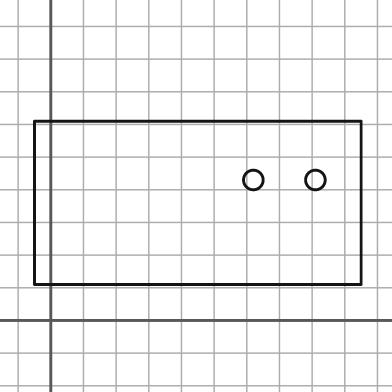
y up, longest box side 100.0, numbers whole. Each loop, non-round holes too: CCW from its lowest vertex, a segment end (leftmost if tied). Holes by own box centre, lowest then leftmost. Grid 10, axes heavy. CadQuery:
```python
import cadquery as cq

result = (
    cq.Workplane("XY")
    .moveTo(-5.0, 11.0)
    .lineTo(95.0, 11.0)
    .lineTo(95.0, 61.0)
    .lineTo(-5.0, 61.0)
    .close()
    .moveTo(62.0, 43.0)
    .circle(3.0)
    .moveTo(81.0, 43.0)
    .circle(3.0)
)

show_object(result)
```